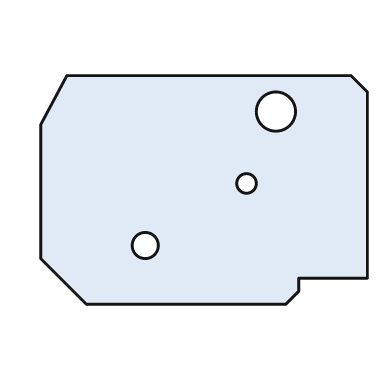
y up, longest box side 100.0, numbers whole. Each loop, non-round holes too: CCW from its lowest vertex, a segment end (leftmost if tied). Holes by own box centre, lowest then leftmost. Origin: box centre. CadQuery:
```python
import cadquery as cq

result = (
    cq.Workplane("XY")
    .moveTo(-36.0, -35.0)
    .lineTo(25.0, -35.0)
    .lineTo(29.0, -31.0)
    .lineTo(29.0, -27.0)
    .lineTo(50.0, -27.0)
    .lineTo(50.0, 30.0)
    .lineTo(45.0, 35.0)
    .lineTo(-42.0, 35.0)
    .lineTo(-50.0, 20.0)
    .lineTo(-50.0, -21.0)
    .close()
    .moveTo(-18.0, -17.0)
    .circle(4.0)
    .moveTo(13.0, 2.0)
    .circle(3.0)
    .moveTo(22.0, 24.0)
    .circle(6.0)
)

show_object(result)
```